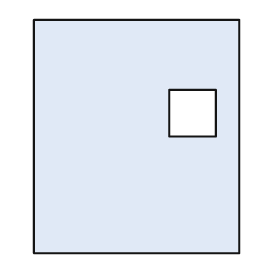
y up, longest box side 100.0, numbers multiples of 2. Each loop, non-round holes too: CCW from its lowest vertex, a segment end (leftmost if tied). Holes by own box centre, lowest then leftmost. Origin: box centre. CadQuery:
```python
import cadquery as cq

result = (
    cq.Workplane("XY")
    .moveTo(-44.0, -50.0)
    .lineTo(44.0, -50.0)
    .lineTo(44.0, 50.0)
    .lineTo(-44.0, 50.0)
    .close()
    .moveTo(14.0, 0.0)
    .lineTo(34.0, 0.0)
    .lineTo(34.0, 20.0)
    .lineTo(14.0, 20.0)
    .close()
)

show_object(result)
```